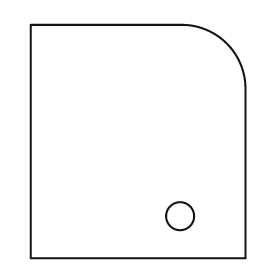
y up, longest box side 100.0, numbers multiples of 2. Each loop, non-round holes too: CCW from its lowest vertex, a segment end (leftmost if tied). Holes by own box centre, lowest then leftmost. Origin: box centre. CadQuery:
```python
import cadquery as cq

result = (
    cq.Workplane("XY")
    .moveTo(-46.0, -50.0)
    .lineTo(46.0, -50.0)
    .lineTo(46.0, 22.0)
    .threePointArc((38.0, 42.0), (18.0, 50.0))
    .lineTo(-46.0, 50.0)
    .close()
    .moveTo(18.0, -32.0)
    .circle(6.0)
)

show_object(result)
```